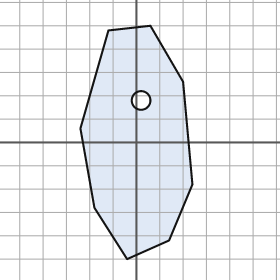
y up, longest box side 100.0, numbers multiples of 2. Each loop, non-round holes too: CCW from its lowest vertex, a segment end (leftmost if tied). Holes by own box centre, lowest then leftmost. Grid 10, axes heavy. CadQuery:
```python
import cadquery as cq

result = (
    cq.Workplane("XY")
    .moveTo(-4.0, -50.0)
    .lineTo(14.0, -42.0)
    .lineTo(24.0, -18.0)
    .lineTo(20.0, 26.0)
    .lineTo(6.0, 50.0)
    .lineTo(-12.0, 48.0)
    .lineTo(-24.0, 6.0)
    .lineTo(-18.0, -28.0)
    .close()
    .moveTo(2.0, 18.0)
    .circle(4.0)
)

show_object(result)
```